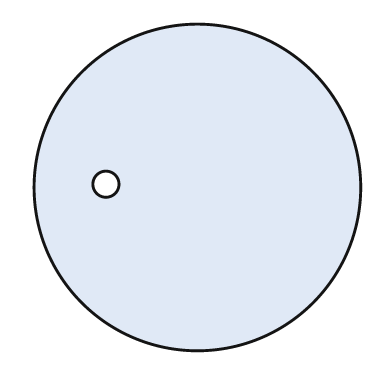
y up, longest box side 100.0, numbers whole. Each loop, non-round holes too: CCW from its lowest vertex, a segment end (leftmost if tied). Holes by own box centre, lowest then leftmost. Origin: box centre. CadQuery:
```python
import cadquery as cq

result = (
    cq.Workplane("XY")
    .moveTo(0.0, 0.0)
    .circle(50.0)
    .moveTo(-28.0, 1.0)
    .circle(4.0)
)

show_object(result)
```